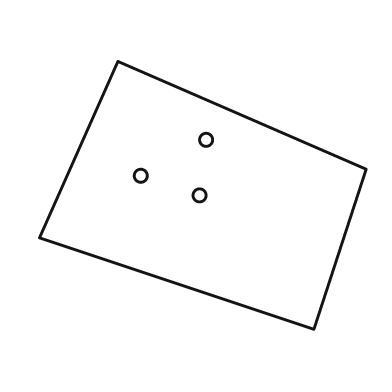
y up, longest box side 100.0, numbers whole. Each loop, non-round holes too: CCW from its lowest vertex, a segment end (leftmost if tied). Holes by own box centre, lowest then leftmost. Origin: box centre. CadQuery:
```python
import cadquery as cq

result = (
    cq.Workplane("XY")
    .moveTo(34.0, -41.0)
    .lineTo(50.0, 8.0)
    .lineTo(-26.0, 41.0)
    .lineTo(-50.0, -13.0)
    .close()
    .moveTo(-1.0, 0.0)
    .circle(2.0)
    .moveTo(-19.0, 6.0)
    .circle(2.0)
    .moveTo(1.0, 17.0)
    .circle(2.0)
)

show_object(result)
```